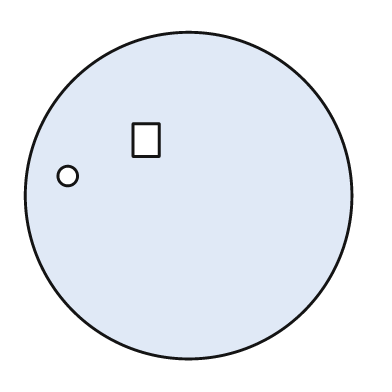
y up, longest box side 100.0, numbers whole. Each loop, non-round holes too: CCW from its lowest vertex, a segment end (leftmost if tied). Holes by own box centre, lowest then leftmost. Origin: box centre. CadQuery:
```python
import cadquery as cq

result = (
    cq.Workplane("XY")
    .moveTo(0.0, 0.0)
    .circle(50.0)
    .moveTo(-37.0, 6.0)
    .circle(3.0)
    .moveTo(-17.0, 12.0)
    .lineTo(-9.0, 12.0)
    .lineTo(-9.0, 22.0)
    .lineTo(-17.0, 22.0)
    .close()
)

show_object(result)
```